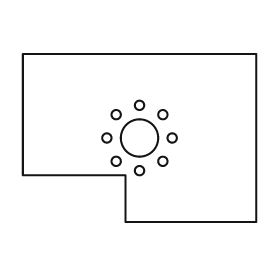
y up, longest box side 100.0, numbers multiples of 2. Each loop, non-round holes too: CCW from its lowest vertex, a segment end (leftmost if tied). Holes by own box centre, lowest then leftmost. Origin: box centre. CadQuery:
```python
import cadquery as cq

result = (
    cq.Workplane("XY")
    .moveTo(-6.0, -36.0)
    .lineTo(50.0, -36.0)
    .lineTo(50.0, 36.0)
    .lineTo(-50.0, 36.0)
    .lineTo(-50.0, -16.0)
    .lineTo(-6.0, -16.0)
    .close()
    .moveTo(0.0, -14.0)
    .circle(2.0)
    .moveTo(-10.0, -10.0)
    .circle(2.0)
    .moveTo(10.0, -10.0)
    .circle(2.0)
    .moveTo(-14.0, 0.0)
    .circle(2.0)
    .moveTo(0.0, 0.0)
    .circle(8.0)
    .moveTo(14.0, 0.0)
    .circle(2.0)
    .moveTo(-10.0, 10.0)
    .circle(2.0)
    .moveTo(10.0, 10.0)
    .circle(2.0)
    .moveTo(0.0, 14.0)
    .circle(2.0)
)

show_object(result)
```